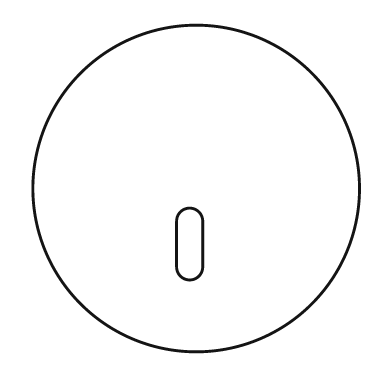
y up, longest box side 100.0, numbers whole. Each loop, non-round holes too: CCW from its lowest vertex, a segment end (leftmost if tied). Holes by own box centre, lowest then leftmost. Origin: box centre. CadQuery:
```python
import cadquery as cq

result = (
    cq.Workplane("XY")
    .moveTo(0.0, 0.0)
    .circle(50.0)
    .moveTo(-6.0, -24.0)
    .threePointArc((-2.0, -28.0), (2.0, -24.0))
    .lineTo(2.0, -10.0)
    .threePointArc((-2.0, -6.0), (-6.0, -10.0))
    .close()
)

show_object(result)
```